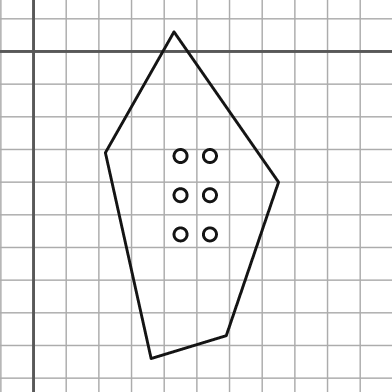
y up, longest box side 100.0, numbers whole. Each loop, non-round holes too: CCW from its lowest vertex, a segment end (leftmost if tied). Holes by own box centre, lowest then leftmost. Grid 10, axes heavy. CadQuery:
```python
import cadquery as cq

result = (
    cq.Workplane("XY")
    .moveTo(36.0, -94.0)
    .lineTo(59.0, -87.0)
    .lineTo(75.0, -40.0)
    .lineTo(43.0, 6.0)
    .lineTo(22.0, -31.0)
    .close()
    .moveTo(45.0, -56.0)
    .circle(2.0)
    .moveTo(54.0, -56.0)
    .circle(2.0)
    .moveTo(45.0, -44.0)
    .circle(2.0)
    .moveTo(54.0, -44.0)
    .circle(2.0)
    .moveTo(45.0, -32.0)
    .circle(2.0)
    .moveTo(54.0, -32.0)
    .circle(2.0)
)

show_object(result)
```